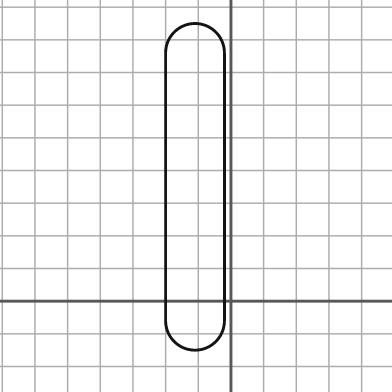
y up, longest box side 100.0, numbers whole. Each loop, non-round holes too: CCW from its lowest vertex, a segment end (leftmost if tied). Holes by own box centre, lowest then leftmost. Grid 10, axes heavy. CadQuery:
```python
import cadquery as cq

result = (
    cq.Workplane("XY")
    .moveTo(-20.0, -6.0)
    .threePointArc((-11.0, -15.0), (-2.0, -6.0))
    .lineTo(-2.0, 76.0)
    .threePointArc((-11.0, 85.0), (-20.0, 76.0))
    .close()
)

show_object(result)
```